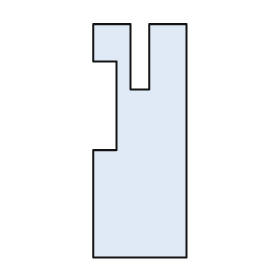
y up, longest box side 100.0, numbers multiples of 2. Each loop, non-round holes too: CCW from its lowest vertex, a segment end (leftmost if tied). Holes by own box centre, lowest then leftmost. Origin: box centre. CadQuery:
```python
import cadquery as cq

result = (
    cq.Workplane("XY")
    .moveTo(-20.0, -50.0)
    .lineTo(20.0, -50.0)
    .lineTo(20.0, 50.0)
    .lineTo(4.0, 50.0)
    .lineTo(4.0, 22.0)
    .lineTo(-4.0, 22.0)
    .lineTo(-4.0, 50.0)
    .lineTo(-20.0, 50.0)
    .lineTo(-20.0, 34.0)
    .lineTo(-10.0, 34.0)
    .lineTo(-10.0, -4.0)
    .lineTo(-20.0, -4.0)
    .close()
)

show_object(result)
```